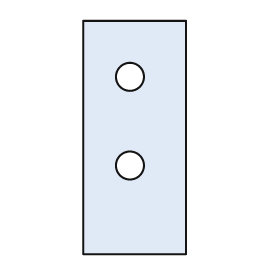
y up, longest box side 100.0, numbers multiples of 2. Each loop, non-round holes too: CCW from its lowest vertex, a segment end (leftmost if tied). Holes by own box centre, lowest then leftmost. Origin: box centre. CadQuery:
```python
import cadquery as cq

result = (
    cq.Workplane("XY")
    .moveTo(-22.0, -50.0)
    .lineTo(22.0, -50.0)
    .lineTo(22.0, 50.0)
    .lineTo(-22.0, 50.0)
    .close()
    .moveTo(-2.0, -12.0)
    .circle(6.0)
    .moveTo(-2.0, 26.0)
    .circle(6.0)
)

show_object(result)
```